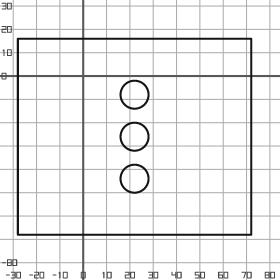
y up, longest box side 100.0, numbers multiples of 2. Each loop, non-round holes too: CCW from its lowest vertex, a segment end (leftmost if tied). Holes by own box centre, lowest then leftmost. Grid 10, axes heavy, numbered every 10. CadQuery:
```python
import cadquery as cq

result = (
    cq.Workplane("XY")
    .moveTo(-28.0, -68.0)
    .lineTo(72.0, -68.0)
    .lineTo(72.0, 16.0)
    .lineTo(-28.0, 16.0)
    .close()
    .moveTo(22.0, -44.0)
    .circle(6.0)
    .moveTo(22.0, -26.0)
    .circle(6.0)
    .moveTo(22.0, -8.0)
    .circle(6.0)
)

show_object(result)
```